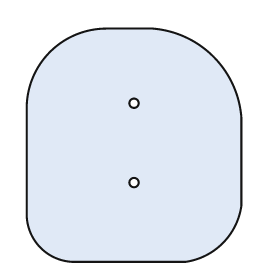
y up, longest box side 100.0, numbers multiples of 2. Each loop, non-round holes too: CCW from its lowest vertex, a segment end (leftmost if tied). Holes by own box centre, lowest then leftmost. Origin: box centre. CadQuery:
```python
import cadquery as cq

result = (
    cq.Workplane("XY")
    .moveTo(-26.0, -50.0)
    .lineTo(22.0, -50.0)
    .threePointArc((38.0, -42.0), (46.0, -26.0))
    .lineTo(46.0, 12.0)
    .threePointArc((34.0, 38.0), (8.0, 50.0))
    .lineTo(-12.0, 50.0)
    .threePointArc((-36.0, 40.0), (-46.0, 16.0))
    .lineTo(-46.0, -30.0)
    .threePointArc((-40.0, -44.0), (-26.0, -50.0))
    .close()
    .moveTo(0.0, -16.0)
    .circle(2.0)
    .moveTo(0.0, 18.0)
    .circle(2.0)
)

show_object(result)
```